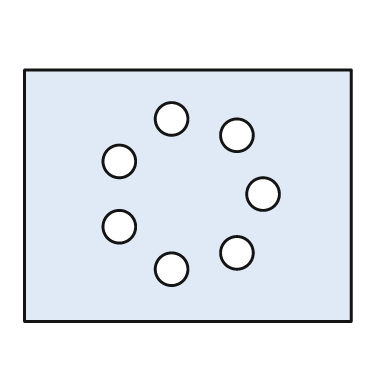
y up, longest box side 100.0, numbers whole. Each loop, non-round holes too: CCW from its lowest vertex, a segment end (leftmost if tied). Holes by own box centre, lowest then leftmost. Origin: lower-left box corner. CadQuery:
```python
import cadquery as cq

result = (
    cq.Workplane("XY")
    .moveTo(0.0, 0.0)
    .lineTo(100.0, 0.0)
    .lineTo(100.0, 77.0)
    .lineTo(0.0, 77.0)
    .close()
    .moveTo(45.0, 16.0)
    .circle(5.0)
    .moveTo(65.0, 21.0)
    .circle(5.0)
    .moveTo(29.0, 29.0)
    .circle(5.0)
    .moveTo(73.0, 39.0)
    .circle(5.0)
    .moveTo(29.0, 49.0)
    .circle(5.0)
    .moveTo(65.0, 57.0)
    .circle(5.0)
    .moveTo(45.0, 62.0)
    .circle(5.0)
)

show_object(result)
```